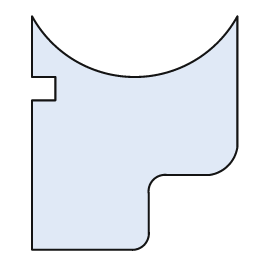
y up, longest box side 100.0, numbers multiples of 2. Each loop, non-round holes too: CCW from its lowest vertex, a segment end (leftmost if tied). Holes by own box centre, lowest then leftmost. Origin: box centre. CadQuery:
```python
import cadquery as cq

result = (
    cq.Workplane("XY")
    .moveTo(-44.0, -50.0)
    .lineTo(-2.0, -50.0)
    .threePointArc((4.0, -48.0), (6.0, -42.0))
    .lineTo(6.0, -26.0)
    .threePointArc((8.0, -20.0), (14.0, -18.0))
    .lineTo(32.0, -18.0)
    .threePointArc((40.0, -14.0), (44.0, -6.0))
    .lineTo(44.0, 50.0)
    .threePointArc((0.0, 24.0), (-44.0, 50.0))
    .lineTo(-44.0, 24.0)
    .lineTo(-34.0, 24.0)
    .lineTo(-34.0, 14.0)
    .lineTo(-44.0, 14.0)
    .close()
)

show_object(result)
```